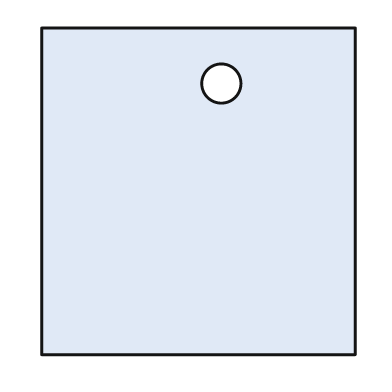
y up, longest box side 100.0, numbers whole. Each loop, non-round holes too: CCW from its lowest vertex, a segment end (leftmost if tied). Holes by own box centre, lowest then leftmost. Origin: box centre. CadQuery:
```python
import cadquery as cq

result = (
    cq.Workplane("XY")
    .moveTo(-48.0, -50.0)
    .lineTo(48.0, -50.0)
    .lineTo(48.0, 50.0)
    .lineTo(-48.0, 50.0)
    .close()
    .moveTo(7.0, 33.0)
    .circle(6.0)
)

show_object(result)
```